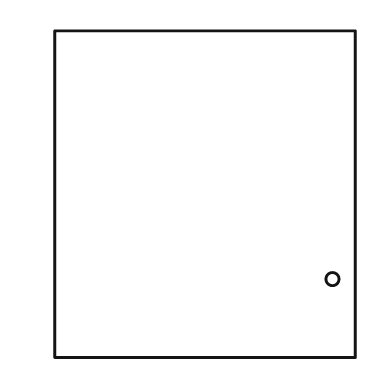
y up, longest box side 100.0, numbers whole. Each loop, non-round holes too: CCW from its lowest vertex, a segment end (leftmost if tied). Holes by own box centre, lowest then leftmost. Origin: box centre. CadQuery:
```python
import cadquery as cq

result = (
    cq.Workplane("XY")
    .moveTo(-46.0, -50.0)
    .lineTo(46.0, -50.0)
    .lineTo(46.0, 50.0)
    .lineTo(-46.0, 50.0)
    .close()
    .moveTo(39.0, -26.0)
    .circle(2.0)
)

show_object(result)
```